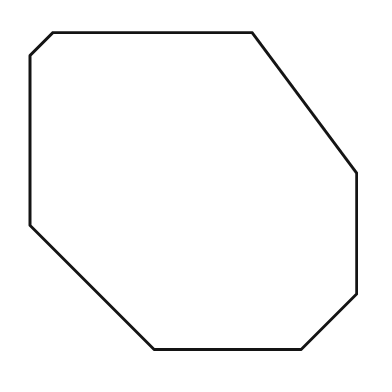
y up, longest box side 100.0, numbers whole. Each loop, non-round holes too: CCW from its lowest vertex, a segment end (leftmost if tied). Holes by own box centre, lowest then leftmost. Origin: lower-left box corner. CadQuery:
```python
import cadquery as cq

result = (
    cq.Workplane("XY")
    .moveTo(38.0, 0.0)
    .lineTo(83.0, 0.0)
    .lineTo(100.0, 17.0)
    .lineTo(100.0, 54.0)
    .lineTo(68.0, 97.0)
    .lineTo(7.0, 97.0)
    .lineTo(0.0, 90.0)
    .lineTo(0.0, 38.0)
    .close()
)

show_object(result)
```